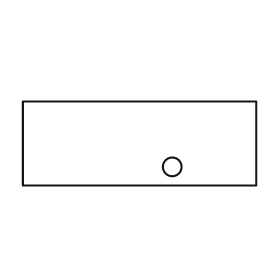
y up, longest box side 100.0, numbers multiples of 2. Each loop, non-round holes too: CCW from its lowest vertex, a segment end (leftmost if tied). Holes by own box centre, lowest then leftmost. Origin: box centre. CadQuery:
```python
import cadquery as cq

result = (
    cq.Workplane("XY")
    .moveTo(-50.0, -18.0)
    .lineTo(50.0, -18.0)
    .lineTo(50.0, 18.0)
    .lineTo(-50.0, 18.0)
    .close()
    .moveTo(14.0, -10.0)
    .circle(4.0)
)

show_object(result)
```